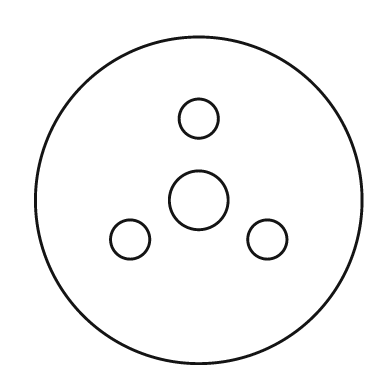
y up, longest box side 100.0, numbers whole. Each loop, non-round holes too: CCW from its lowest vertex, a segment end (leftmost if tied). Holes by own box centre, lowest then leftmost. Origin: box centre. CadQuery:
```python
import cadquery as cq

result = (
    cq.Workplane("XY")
    .moveTo(0.0, 0.0)
    .circle(50.0)
    .moveTo(-21.0, -12.0)
    .circle(6.0)
    .moveTo(21.0, -12.0)
    .circle(6.0)
    .moveTo(0.0, 0.0)
    .circle(9.0)
    .moveTo(0.0, 25.0)
    .circle(6.0)
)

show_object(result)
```